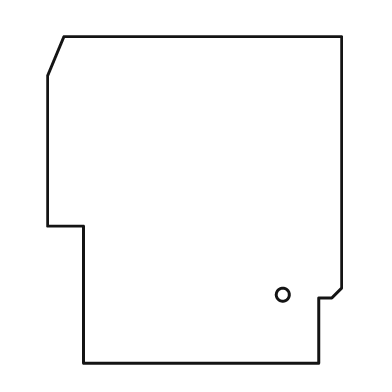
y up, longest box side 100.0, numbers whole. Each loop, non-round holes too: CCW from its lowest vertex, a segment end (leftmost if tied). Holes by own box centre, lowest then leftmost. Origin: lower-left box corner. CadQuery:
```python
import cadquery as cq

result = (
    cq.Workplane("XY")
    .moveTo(11.0, 0.0)
    .lineTo(83.0, 0.0)
    .lineTo(83.0, 20.0)
    .lineTo(87.0, 20.0)
    .lineTo(90.0, 23.0)
    .lineTo(90.0, 100.0)
    .lineTo(5.0, 100.0)
    .lineTo(0.0, 88.0)
    .lineTo(0.0, 42.0)
    .lineTo(11.0, 42.0)
    .close()
    .moveTo(72.0, 21.0)
    .circle(2.0)
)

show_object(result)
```